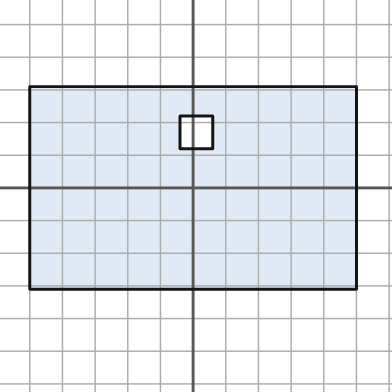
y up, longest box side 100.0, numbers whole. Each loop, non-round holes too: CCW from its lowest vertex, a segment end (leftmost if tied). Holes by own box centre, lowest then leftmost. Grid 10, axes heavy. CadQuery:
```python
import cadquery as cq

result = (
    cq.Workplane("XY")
    .moveTo(-50.0, -31.0)
    .lineTo(50.0, -31.0)
    .lineTo(50.0, 31.0)
    .lineTo(-50.0, 31.0)
    .close()
    .moveTo(-4.0, 12.0)
    .lineTo(6.0, 12.0)
    .lineTo(6.0, 22.0)
    .lineTo(-4.0, 22.0)
    .close()
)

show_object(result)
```